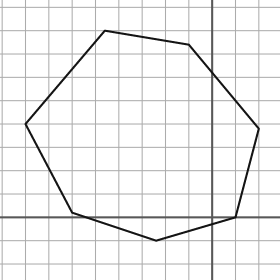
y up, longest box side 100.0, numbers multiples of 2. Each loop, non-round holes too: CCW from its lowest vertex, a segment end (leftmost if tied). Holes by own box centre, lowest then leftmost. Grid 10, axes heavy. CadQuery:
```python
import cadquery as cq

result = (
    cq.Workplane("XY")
    .moveTo(-24.0, -10.0)
    .lineTo(10.0, 0.0)
    .lineTo(20.0, 38.0)
    .lineTo(-10.0, 74.0)
    .lineTo(-46.0, 80.0)
    .lineTo(-80.0, 40.0)
    .lineTo(-60.0, 2.0)
    .close()
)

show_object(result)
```